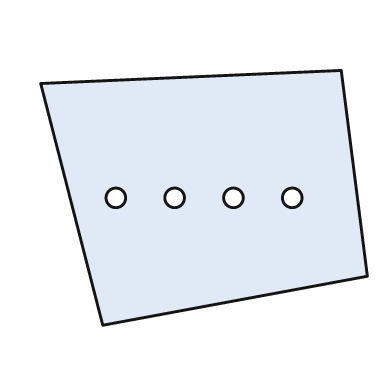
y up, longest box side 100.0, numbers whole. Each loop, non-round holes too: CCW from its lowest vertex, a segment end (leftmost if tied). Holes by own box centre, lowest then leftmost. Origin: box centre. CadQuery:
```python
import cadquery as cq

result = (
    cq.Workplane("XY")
    .moveTo(-31.0, -39.0)
    .lineTo(50.0, -24.0)
    .lineTo(42.0, 39.0)
    .lineTo(-50.0, 35.0)
    .close()
    .moveTo(-27.0, 0.0)
    .circle(3.0)
    .moveTo(-9.0, 0.0)
    .circle(3.0)
    .moveTo(9.0, 0.0)
    .circle(3.0)
    .moveTo(27.0, 0.0)
    .circle(3.0)
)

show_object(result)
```